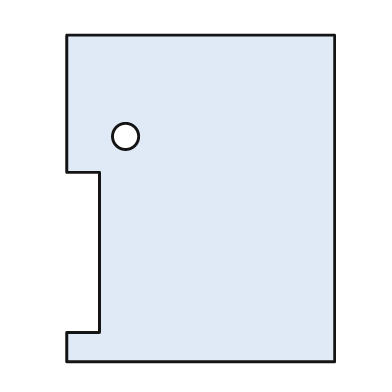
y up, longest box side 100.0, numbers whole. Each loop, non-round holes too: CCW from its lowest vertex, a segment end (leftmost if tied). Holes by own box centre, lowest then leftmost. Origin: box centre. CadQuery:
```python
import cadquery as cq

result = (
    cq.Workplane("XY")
    .moveTo(-41.0, -50.0)
    .lineTo(41.0, -50.0)
    .lineTo(41.0, 50.0)
    .lineTo(-41.0, 50.0)
    .lineTo(-41.0, 8.0)
    .lineTo(-31.0, 8.0)
    .lineTo(-31.0, -41.0)
    .lineTo(-41.0, -41.0)
    .close()
    .moveTo(-23.0, 19.0)
    .circle(4.0)
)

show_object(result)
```